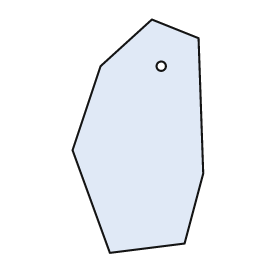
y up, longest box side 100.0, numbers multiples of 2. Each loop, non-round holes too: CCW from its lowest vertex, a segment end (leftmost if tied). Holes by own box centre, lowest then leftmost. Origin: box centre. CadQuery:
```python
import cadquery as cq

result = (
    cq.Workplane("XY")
    .moveTo(-12.0, -50.0)
    .lineTo(20.0, -46.0)
    .lineTo(28.0, -16.0)
    .lineTo(26.0, 42.0)
    .lineTo(6.0, 50.0)
    .lineTo(-16.0, 30.0)
    .lineTo(-28.0, -6.0)
    .close()
    .moveTo(10.0, 30.0)
    .circle(2.0)
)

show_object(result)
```